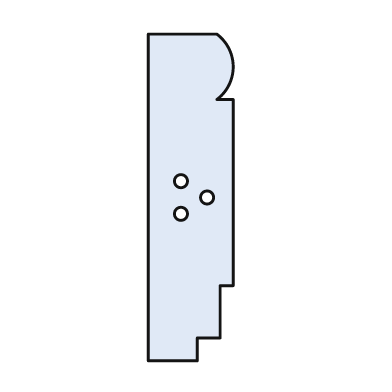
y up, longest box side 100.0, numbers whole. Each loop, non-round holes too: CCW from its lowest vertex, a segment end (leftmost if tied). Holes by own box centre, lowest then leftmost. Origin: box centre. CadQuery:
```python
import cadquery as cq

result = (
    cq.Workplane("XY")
    .moveTo(-13.0, -50.0)
    .lineTo(2.0, -50.0)
    .lineTo(2.0, -43.0)
    .lineTo(9.0, -43.0)
    .lineTo(9.0, -27.0)
    .lineTo(13.0, -27.0)
    .lineTo(13.0, 30.0)
    .lineTo(8.0, 30.0)
    .threePointArc((13.0, 40.0), (8.0, 50.0))
    .lineTo(-13.0, 50.0)
    .close()
    .moveTo(-3.0, -5.0)
    .circle(2.0)
    .moveTo(5.0, 0.0)
    .circle(2.0)
    .moveTo(-3.0, 5.0)
    .circle(2.0)
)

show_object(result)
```